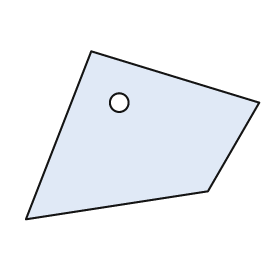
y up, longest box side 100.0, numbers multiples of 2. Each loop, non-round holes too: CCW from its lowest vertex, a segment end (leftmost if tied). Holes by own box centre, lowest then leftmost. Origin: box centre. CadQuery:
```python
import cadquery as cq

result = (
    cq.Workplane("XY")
    .moveTo(-50.0, -36.0)
    .lineTo(28.0, -24.0)
    .lineTo(50.0, 14.0)
    .lineTo(-22.0, 36.0)
    .close()
    .moveTo(-10.0, 14.0)
    .circle(4.0)
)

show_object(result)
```